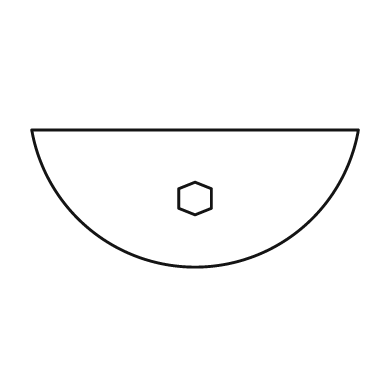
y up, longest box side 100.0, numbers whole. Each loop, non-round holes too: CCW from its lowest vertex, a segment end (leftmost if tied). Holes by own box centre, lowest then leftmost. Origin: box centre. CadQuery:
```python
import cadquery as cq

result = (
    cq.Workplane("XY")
    .moveTo(-50.0, 21.0)
    .threePointArc((0.0, -21.0), (50.0, 21.0))
    .close()
    .moveTo(0.0, -5.0)
    .lineTo(5.0, -3.0)
    .lineTo(5.0, 3.0)
    .lineTo(0.0, 5.0)
    .lineTo(-5.0, 3.0)
    .lineTo(-5.0, -3.0)
    .close()
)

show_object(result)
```